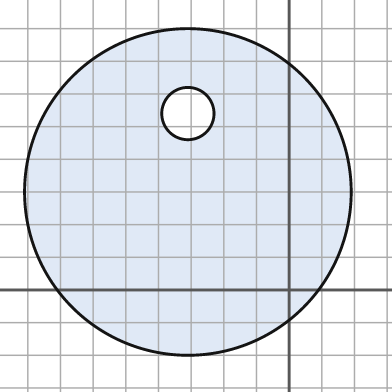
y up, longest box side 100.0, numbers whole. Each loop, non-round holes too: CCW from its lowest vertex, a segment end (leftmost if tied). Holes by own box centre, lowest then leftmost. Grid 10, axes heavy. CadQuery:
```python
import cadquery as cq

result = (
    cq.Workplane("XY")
    .moveTo(-31.0, 30.0)
    .circle(50.0)
    .moveTo(-31.0, 54.0)
    .circle(8.0)
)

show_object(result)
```